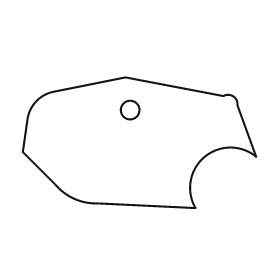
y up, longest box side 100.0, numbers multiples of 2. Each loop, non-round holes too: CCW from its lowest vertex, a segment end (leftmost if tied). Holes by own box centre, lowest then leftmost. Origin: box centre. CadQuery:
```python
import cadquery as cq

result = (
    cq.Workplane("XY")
    .moveTo(24.0, -28.0)
    .threePointArc((28.0, -6.0), (50.0, -6.0))
    .lineTo(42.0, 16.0)
    .threePointArc((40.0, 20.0), (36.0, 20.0))
    .lineTo(-6.0, 28.0)
    .lineTo(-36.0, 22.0)
    .threePointArc((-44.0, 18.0), (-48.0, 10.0))
    .lineTo(-50.0, -4.0)
    .lineTo(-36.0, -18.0)
    .threePointArc((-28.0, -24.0), (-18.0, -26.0))
    .close()
    .moveTo(-4.0, 14.0)
    .circle(4.0)
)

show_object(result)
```